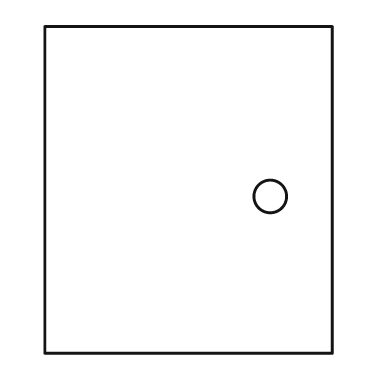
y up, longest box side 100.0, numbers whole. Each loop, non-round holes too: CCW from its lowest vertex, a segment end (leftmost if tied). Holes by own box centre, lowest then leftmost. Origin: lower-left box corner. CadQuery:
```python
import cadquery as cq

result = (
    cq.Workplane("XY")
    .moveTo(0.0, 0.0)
    .lineTo(88.0, 0.0)
    .lineTo(88.0, 100.0)
    .lineTo(0.0, 100.0)
    .close()
    .moveTo(69.0, 48.0)
    .circle(5.0)
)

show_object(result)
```